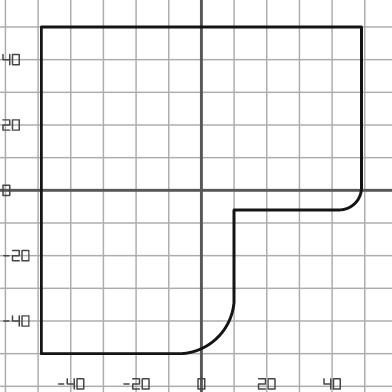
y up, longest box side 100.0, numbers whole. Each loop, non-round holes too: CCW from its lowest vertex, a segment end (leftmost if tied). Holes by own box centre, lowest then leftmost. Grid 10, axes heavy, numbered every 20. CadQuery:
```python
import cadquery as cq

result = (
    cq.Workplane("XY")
    .moveTo(-49.0, -50.0)
    .lineTo(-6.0, -50.0)
    .threePointArc((5.0, -45.0), (10.0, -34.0))
    .lineTo(10.0, -6.0)
    .lineTo(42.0, -6.0)
    .threePointArc((47.0, -4.0), (49.0, 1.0))
    .lineTo(49.0, 50.0)
    .lineTo(-49.0, 50.0)
    .close()
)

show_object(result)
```